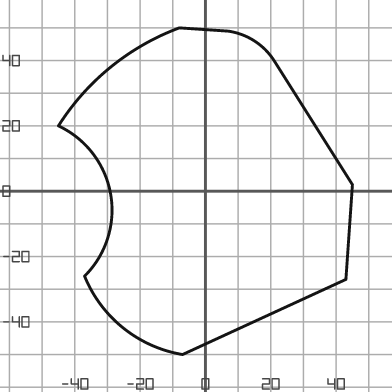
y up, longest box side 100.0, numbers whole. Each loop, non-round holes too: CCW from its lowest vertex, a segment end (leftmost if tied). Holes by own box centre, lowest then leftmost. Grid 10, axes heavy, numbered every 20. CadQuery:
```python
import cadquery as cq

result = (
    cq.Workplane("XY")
    .moveTo(-7.0, -50.0)
    .lineTo(43.0, -27.0)
    .lineTo(45.0, 2.0)
    .lineTo(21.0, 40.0)
    .threePointArc((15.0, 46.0), (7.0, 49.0))
    .lineTo(-8.0, 50.0)
    .threePointArc((-29.0, 38.0), (-45.0, 20.0))
    .threePointArc((-29.0, -1.0), (-37.0, -26.0))
    .threePointArc((-25.0, -42.0), (-7.0, -50.0))
    .close()
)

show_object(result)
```